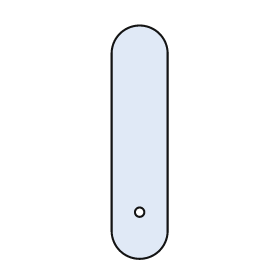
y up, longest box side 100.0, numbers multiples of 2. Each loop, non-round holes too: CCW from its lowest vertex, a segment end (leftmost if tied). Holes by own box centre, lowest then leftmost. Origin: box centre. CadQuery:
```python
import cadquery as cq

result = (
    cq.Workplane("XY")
    .moveTo(-12.0, -38.0)
    .threePointArc((0.0, -50.0), (12.0, -38.0))
    .lineTo(12.0, 38.0)
    .threePointArc((0.0, 50.0), (-12.0, 38.0))
    .close()
    .moveTo(0.0, -30.0)
    .circle(2.0)
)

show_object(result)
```